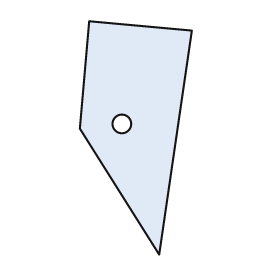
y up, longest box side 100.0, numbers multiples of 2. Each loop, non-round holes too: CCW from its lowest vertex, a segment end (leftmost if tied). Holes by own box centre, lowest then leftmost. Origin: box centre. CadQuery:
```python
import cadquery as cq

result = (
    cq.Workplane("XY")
    .moveTo(10.0, -50.0)
    .lineTo(24.0, 46.0)
    .lineTo(-20.0, 50.0)
    .lineTo(-24.0, 4.0)
    .close()
    .moveTo(-6.0, 6.0)
    .circle(4.0)
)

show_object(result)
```